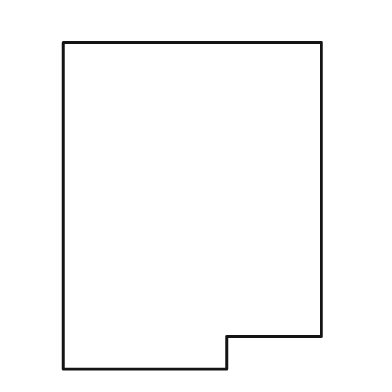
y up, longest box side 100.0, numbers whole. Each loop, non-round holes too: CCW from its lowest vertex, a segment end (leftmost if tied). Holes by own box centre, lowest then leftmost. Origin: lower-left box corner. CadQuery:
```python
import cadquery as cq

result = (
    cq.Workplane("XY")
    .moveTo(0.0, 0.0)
    .lineTo(50.0, 0.0)
    .lineTo(50.0, 10.0)
    .lineTo(79.0, 10.0)
    .lineTo(79.0, 100.0)
    .lineTo(0.0, 100.0)
    .close()
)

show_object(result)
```